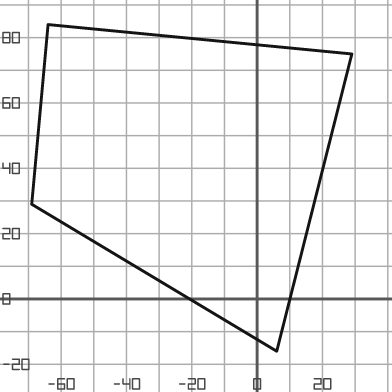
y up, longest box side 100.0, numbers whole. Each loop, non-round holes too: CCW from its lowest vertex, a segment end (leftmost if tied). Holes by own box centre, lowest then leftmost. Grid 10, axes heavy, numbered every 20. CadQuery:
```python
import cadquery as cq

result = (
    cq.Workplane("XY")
    .moveTo(6.0, -16.0)
    .lineTo(29.0, 75.0)
    .lineTo(-64.0, 84.0)
    .lineTo(-69.0, 29.0)
    .close()
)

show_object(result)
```